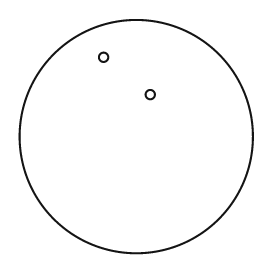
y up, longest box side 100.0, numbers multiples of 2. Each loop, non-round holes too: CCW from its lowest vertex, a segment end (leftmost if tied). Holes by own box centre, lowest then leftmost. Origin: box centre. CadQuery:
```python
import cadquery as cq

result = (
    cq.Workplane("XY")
    .moveTo(0.0, 0.0)
    .circle(50.0)
    .moveTo(6.0, 18.0)
    .circle(2.0)
    .moveTo(-14.0, 34.0)
    .circle(2.0)
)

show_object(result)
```